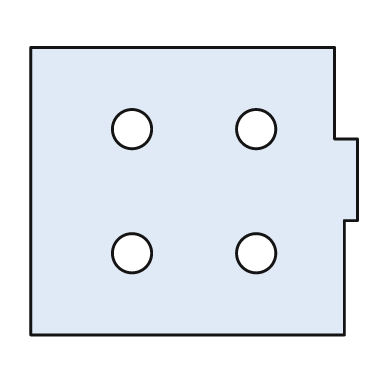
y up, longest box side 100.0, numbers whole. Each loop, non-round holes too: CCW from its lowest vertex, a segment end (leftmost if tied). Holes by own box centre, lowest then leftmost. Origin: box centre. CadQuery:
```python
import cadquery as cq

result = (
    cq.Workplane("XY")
    .moveTo(-50.0, -44.0)
    .lineTo(46.0, -44.0)
    .lineTo(46.0, -9.0)
    .lineTo(50.0, -9.0)
    .lineTo(50.0, 16.0)
    .lineTo(43.0, 16.0)
    .lineTo(43.0, 44.0)
    .lineTo(-50.0, 44.0)
    .close()
    .moveTo(-19.0, -19.0)
    .circle(6.0)
    .moveTo(19.0, -19.0)
    .circle(6.0)
    .moveTo(-19.0, 19.0)
    .circle(6.0)
    .moveTo(19.0, 19.0)
    .circle(6.0)
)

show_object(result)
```